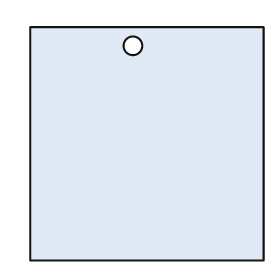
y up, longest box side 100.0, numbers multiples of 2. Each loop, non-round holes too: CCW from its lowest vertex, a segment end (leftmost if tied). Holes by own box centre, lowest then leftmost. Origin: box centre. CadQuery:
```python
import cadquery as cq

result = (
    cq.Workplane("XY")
    .moveTo(-50.0, -50.0)
    .lineTo(50.0, -50.0)
    .lineTo(50.0, 50.0)
    .lineTo(-50.0, 50.0)
    .close()
    .moveTo(-6.0, 42.0)
    .circle(4.0)
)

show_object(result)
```